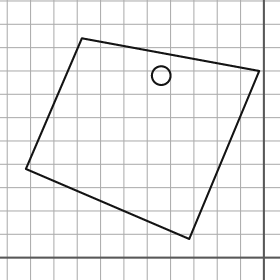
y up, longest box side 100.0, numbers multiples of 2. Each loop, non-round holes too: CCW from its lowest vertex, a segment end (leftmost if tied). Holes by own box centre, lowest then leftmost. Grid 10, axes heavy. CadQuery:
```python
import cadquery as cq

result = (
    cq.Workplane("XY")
    .moveTo(-32.0, 8.0)
    .lineTo(-2.0, 80.0)
    .lineTo(-78.0, 94.0)
    .lineTo(-102.0, 38.0)
    .close()
    .moveTo(-44.0, 78.0)
    .circle(4.0)
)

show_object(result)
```